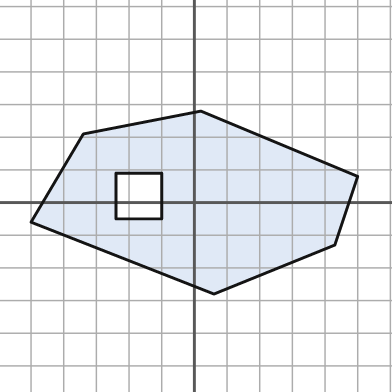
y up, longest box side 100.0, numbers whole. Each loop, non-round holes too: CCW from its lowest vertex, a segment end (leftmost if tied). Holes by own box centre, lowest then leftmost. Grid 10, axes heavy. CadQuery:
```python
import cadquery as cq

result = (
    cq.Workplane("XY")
    .moveTo(6.0, -28.0)
    .lineTo(43.0, -13.0)
    .lineTo(50.0, 8.0)
    .lineTo(2.0, 28.0)
    .lineTo(-34.0, 21.0)
    .lineTo(-50.0, -6.0)
    .close()
    .moveTo(-24.0, -5.0)
    .lineTo(-10.0, -5.0)
    .lineTo(-10.0, 9.0)
    .lineTo(-24.0, 9.0)
    .close()
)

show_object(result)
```